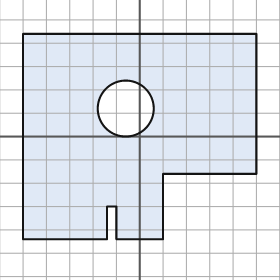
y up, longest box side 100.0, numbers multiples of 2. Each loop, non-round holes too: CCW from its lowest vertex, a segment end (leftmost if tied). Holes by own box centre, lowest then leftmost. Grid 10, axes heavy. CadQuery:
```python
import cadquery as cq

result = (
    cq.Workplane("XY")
    .moveTo(-50.0, -44.0)
    .lineTo(-14.0, -44.0)
    .lineTo(-14.0, -30.0)
    .lineTo(-10.0, -30.0)
    .lineTo(-10.0, -44.0)
    .lineTo(10.0, -44.0)
    .lineTo(10.0, -16.0)
    .lineTo(50.0, -16.0)
    .lineTo(50.0, 44.0)
    .lineTo(-50.0, 44.0)
    .close()
    .moveTo(-6.0, 12.0)
    .circle(12.0)
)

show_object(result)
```